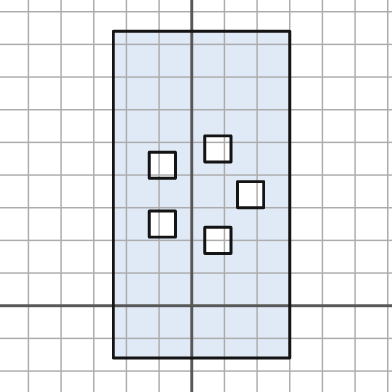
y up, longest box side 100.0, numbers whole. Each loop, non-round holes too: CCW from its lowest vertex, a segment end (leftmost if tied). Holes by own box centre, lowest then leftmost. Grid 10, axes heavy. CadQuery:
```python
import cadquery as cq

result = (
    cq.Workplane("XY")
    .moveTo(-24.0, -16.0)
    .lineTo(30.0, -16.0)
    .lineTo(30.0, 84.0)
    .lineTo(-24.0, 84.0)
    .close()
    .moveTo(4.0, 16.0)
    .lineTo(12.0, 16.0)
    .lineTo(12.0, 24.0)
    .lineTo(4.0, 24.0)
    .close()
    .moveTo(-13.0, 21.0)
    .lineTo(-5.0, 21.0)
    .lineTo(-5.0, 29.0)
    .lineTo(-13.0, 29.0)
    .close()
    .moveTo(14.0, 30.0)
    .lineTo(22.0, 30.0)
    .lineTo(22.0, 38.0)
    .lineTo(14.0, 38.0)
    .close()
    .moveTo(-13.0, 39.0)
    .lineTo(-5.0, 39.0)
    .lineTo(-5.0, 47.0)
    .lineTo(-13.0, 47.0)
    .close()
    .moveTo(4.0, 44.0)
    .lineTo(12.0, 44.0)
    .lineTo(12.0, 52.0)
    .lineTo(4.0, 52.0)
    .close()
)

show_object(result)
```